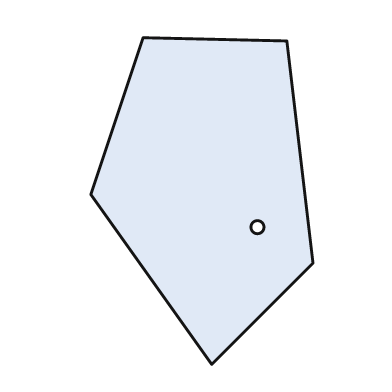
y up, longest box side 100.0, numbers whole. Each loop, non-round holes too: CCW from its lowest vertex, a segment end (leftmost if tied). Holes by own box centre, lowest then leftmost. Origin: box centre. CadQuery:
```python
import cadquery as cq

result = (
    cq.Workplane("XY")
    .moveTo(3.0, -50.0)
    .lineTo(34.0, -19.0)
    .lineTo(26.0, 49.0)
    .lineTo(-18.0, 50.0)
    .lineTo(-34.0, 2.0)
    .close()
    .moveTo(17.0, -8.0)
    .circle(2.0)
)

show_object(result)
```